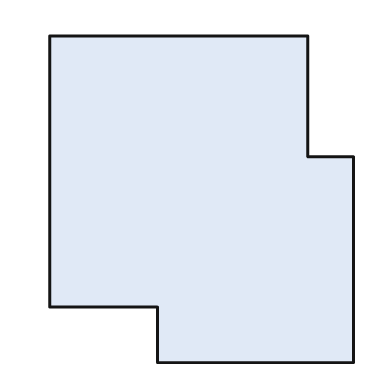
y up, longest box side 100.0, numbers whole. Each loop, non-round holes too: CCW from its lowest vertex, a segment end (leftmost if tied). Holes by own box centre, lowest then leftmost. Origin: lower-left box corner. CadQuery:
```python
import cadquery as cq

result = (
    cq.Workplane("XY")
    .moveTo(33.0, 0.0)
    .lineTo(93.0, 0.0)
    .lineTo(93.0, 63.0)
    .lineTo(79.0, 63.0)
    .lineTo(79.0, 100.0)
    .lineTo(0.0, 100.0)
    .lineTo(0.0, 17.0)
    .lineTo(33.0, 17.0)
    .close()
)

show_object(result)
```